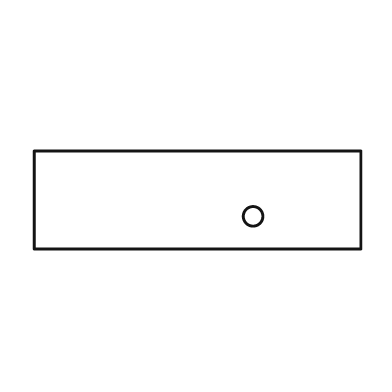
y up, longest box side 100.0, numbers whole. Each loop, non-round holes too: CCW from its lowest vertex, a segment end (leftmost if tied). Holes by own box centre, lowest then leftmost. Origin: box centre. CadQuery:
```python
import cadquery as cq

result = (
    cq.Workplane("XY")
    .moveTo(-50.0, -15.0)
    .lineTo(50.0, -15.0)
    .lineTo(50.0, 15.0)
    .lineTo(-50.0, 15.0)
    .close()
    .moveTo(17.0, -5.0)
    .circle(3.0)
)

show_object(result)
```